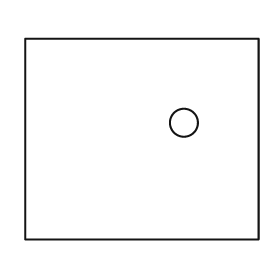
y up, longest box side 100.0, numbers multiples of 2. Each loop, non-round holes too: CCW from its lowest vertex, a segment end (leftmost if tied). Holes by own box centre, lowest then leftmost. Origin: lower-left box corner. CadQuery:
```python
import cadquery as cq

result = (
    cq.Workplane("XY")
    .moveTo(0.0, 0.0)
    .lineTo(100.0, 0.0)
    .lineTo(100.0, 86.0)
    .lineTo(0.0, 86.0)
    .close()
    .moveTo(68.0, 50.0)
    .circle(6.0)
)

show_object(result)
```